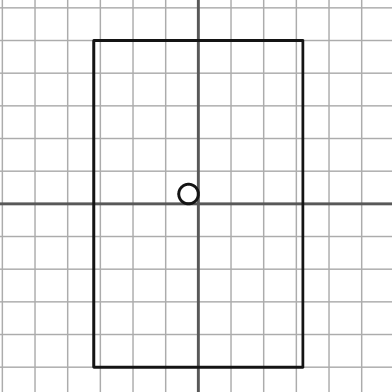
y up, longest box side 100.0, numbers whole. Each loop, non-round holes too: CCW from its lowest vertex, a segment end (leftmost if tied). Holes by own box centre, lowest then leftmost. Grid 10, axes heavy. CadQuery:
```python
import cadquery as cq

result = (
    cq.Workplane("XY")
    .moveTo(-32.0, -50.0)
    .lineTo(32.0, -50.0)
    .lineTo(32.0, 50.0)
    .lineTo(-32.0, 50.0)
    .close()
    .moveTo(-3.0, 3.0)
    .circle(3.0)
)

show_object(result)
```